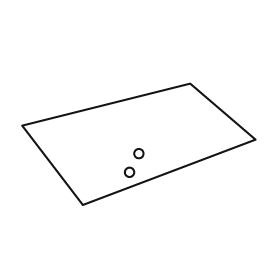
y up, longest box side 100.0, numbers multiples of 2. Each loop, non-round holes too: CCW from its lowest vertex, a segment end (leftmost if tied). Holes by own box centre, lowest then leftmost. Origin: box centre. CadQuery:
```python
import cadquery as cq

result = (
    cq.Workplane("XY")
    .moveTo(-24.0, -26.0)
    .lineTo(50.0, 2.0)
    .lineTo(22.0, 26.0)
    .lineTo(-50.0, 8.0)
    .close()
    .moveTo(-4.0, -12.0)
    .circle(2.0)
    .moveTo(0.0, -4.0)
    .circle(2.0)
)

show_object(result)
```